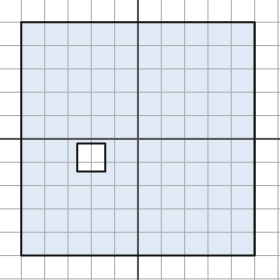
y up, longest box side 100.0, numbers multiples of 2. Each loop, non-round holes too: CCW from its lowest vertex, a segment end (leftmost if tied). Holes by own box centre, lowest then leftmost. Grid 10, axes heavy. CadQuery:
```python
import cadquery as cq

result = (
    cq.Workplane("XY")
    .moveTo(-50.0, -50.0)
    .lineTo(50.0, -50.0)
    .lineTo(50.0, 50.0)
    .lineTo(-50.0, 50.0)
    .close()
    .moveTo(-26.0, -14.0)
    .lineTo(-14.0, -14.0)
    .lineTo(-14.0, -2.0)
    .lineTo(-26.0, -2.0)
    .close()
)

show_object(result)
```